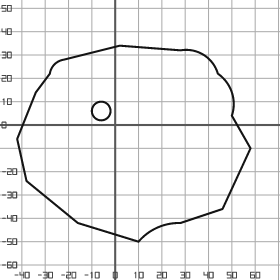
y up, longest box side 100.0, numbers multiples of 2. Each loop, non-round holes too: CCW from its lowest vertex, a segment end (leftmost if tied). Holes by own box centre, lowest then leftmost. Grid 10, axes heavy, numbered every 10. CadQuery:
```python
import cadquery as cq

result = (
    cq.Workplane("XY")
    .moveTo(10.0, -50.0)
    .threePointArc((18.0, -44.0), (28.0, -42.0))
    .lineTo(46.0, -36.0)
    .lineTo(58.0, -10.0)
    .lineTo(50.0, 4.0)
    .threePointArc((50.0, 14.0), (44.0, 22.0))
    .threePointArc((38.0, 30.0), (28.0, 32.0))
    .lineTo(2.0, 34.0)
    .lineTo(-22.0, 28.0)
    .threePointArc((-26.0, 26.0), (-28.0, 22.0))
    .lineTo(-34.0, 14.0)
    .lineTo(-42.0, -6.0)
    .lineTo(-38.0, -24.0)
    .lineTo(-16.0, -42.0)
    .close()
    .moveTo(-6.0, 6.0)
    .circle(4.0)
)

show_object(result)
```